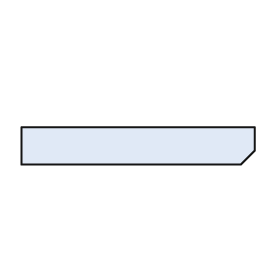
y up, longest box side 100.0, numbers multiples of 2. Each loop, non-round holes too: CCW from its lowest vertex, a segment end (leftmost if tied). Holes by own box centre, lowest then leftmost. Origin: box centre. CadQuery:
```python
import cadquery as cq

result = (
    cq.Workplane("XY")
    .moveTo(-50.0, -8.0)
    .lineTo(44.0, -8.0)
    .lineTo(50.0, -2.0)
    .lineTo(50.0, 8.0)
    .lineTo(-50.0, 8.0)
    .close()
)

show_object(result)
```